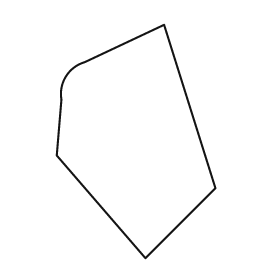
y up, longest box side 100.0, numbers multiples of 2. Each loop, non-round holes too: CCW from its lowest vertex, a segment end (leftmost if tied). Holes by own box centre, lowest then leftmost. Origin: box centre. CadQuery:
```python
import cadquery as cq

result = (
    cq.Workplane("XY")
    .moveTo(4.0, -50.0)
    .lineTo(34.0, -20.0)
    .lineTo(12.0, 50.0)
    .lineTo(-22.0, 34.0)
    .threePointArc((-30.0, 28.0), (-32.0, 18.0))
    .lineTo(-34.0, -6.0)
    .close()
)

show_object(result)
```